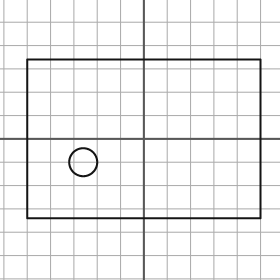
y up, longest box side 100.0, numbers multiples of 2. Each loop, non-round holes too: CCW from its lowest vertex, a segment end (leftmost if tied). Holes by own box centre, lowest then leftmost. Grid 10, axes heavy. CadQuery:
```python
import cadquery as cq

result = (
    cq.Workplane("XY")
    .moveTo(-50.0, -34.0)
    .lineTo(50.0, -34.0)
    .lineTo(50.0, 34.0)
    .lineTo(-50.0, 34.0)
    .close()
    .moveTo(-26.0, -10.0)
    .circle(6.0)
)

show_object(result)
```